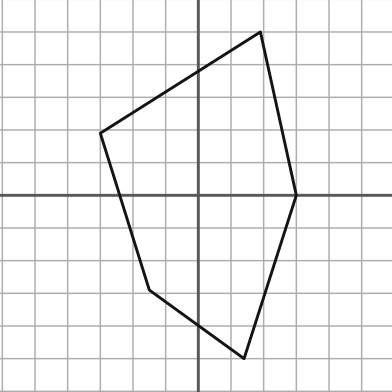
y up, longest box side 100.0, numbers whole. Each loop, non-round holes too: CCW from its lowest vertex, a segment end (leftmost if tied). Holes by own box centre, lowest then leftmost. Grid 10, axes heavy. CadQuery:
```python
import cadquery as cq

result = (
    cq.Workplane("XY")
    .moveTo(14.0, -50.0)
    .lineTo(30.0, 0.0)
    .lineTo(19.0, 50.0)
    .lineTo(-30.0, 19.0)
    .lineTo(-15.0, -29.0)
    .close()
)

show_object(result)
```